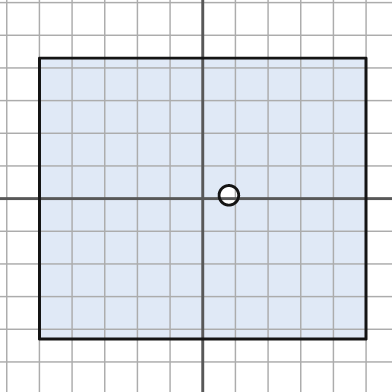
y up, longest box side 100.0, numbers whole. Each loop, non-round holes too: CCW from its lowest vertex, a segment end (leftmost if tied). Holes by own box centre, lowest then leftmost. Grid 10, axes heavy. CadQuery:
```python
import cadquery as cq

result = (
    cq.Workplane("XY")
    .moveTo(-50.0, -43.0)
    .lineTo(50.0, -43.0)
    .lineTo(50.0, 43.0)
    .lineTo(-50.0, 43.0)
    .close()
    .moveTo(8.0, 1.0)
    .circle(3.0)
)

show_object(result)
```